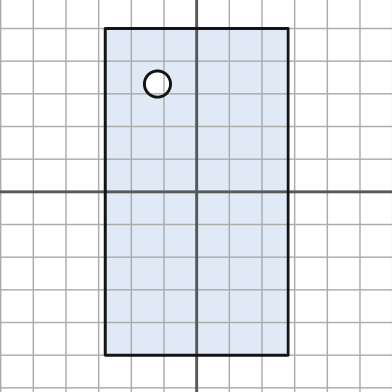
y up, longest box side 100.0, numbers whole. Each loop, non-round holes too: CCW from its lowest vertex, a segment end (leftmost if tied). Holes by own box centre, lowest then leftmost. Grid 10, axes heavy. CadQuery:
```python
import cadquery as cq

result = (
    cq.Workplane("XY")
    .moveTo(-28.0, -50.0)
    .lineTo(28.0, -50.0)
    .lineTo(28.0, 50.0)
    .lineTo(-28.0, 50.0)
    .close()
    .moveTo(-12.0, 33.0)
    .circle(4.0)
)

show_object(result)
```